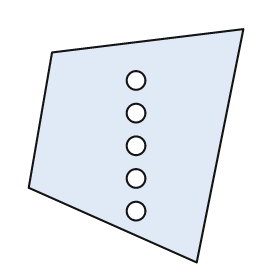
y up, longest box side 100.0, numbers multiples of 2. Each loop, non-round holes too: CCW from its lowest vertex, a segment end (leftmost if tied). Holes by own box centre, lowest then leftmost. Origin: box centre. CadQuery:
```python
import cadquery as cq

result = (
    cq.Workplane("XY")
    .moveTo(26.0, -50.0)
    .lineTo(46.0, 50.0)
    .lineTo(-36.0, 40.0)
    .lineTo(-46.0, -18.0)
    .close()
    .moveTo(0.0, -28.0)
    .circle(4.0)
    .moveTo(0.0, -14.0)
    .circle(4.0)
    .moveTo(0.0, 0.0)
    .circle(4.0)
    .moveTo(0.0, 14.0)
    .circle(4.0)
    .moveTo(0.0, 28.0)
    .circle(4.0)
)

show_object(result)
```